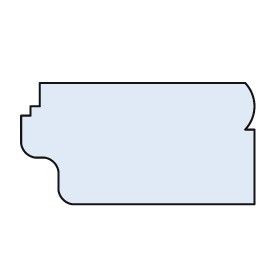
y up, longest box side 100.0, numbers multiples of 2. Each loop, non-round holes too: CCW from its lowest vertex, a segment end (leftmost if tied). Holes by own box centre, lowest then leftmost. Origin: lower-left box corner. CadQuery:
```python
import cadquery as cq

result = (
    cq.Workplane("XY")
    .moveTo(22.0, 0.0)
    .lineTo(100.0, 0.0)
    .lineTo(100.0, 32.0)
    .lineTo(96.0, 32.0)
    .threePointArc((100.0, 42.0), (96.0, 52.0))
    .lineTo(8.0, 52.0)
    .lineTo(8.0, 42.0)
    .lineTo(4.0, 42.0)
    .lineTo(4.0, 38.0)
    .lineTo(0.0, 38.0)
    .lineTo(0.0, 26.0)
    .threePointArc((2.0, 22.0), (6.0, 20.0))
    .lineTo(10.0, 20.0)
    .threePointArc((14.0, 18.0), (16.0, 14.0))
    .lineTo(16.0, 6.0)
    .threePointArc((18.0, 2.0), (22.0, 0.0))
    .close()
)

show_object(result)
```